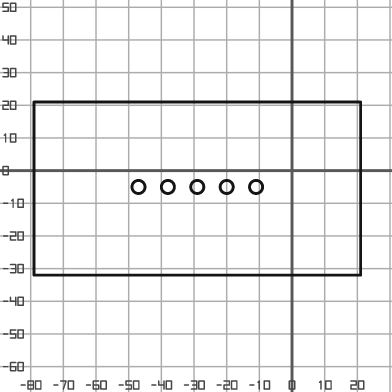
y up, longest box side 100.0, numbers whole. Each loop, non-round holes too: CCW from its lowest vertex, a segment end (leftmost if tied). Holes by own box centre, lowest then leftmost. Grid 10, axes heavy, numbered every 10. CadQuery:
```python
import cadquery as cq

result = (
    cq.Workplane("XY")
    .moveTo(-79.0, -32.0)
    .lineTo(21.0, -32.0)
    .lineTo(21.0, 21.0)
    .lineTo(-79.0, 21.0)
    .close()
    .moveTo(-47.0, -5.0)
    .circle(2.0)
    .moveTo(-38.0, -5.0)
    .circle(2.0)
    .moveTo(-29.0, -5.0)
    .circle(2.0)
    .moveTo(-20.0, -5.0)
    .circle(2.0)
    .moveTo(-11.0, -5.0)
    .circle(2.0)
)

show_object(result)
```